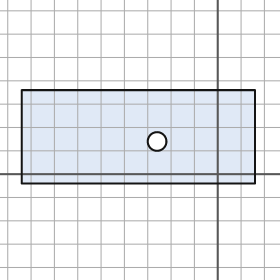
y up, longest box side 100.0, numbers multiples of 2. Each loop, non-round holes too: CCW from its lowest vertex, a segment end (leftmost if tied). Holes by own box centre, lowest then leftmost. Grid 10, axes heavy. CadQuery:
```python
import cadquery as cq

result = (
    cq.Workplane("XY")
    .moveTo(-84.0, -4.0)
    .lineTo(16.0, -4.0)
    .lineTo(16.0, 36.0)
    .lineTo(-84.0, 36.0)
    .close()
    .moveTo(-26.0, 14.0)
    .circle(4.0)
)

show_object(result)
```